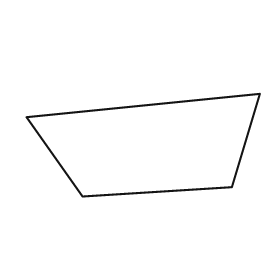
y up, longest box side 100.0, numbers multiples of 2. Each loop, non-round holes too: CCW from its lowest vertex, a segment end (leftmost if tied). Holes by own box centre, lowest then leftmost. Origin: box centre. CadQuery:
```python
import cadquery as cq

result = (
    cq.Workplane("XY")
    .moveTo(-26.0, -22.0)
    .lineTo(38.0, -18.0)
    .lineTo(50.0, 22.0)
    .lineTo(-50.0, 12.0)
    .close()
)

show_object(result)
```